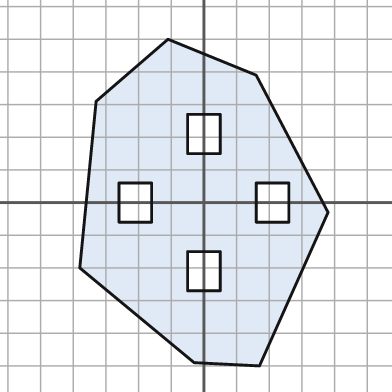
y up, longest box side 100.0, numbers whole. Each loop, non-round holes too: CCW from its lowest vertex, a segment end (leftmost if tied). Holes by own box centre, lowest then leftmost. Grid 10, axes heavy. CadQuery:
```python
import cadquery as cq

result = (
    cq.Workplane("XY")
    .moveTo(17.0, -50.0)
    .lineTo(38.0, -3.0)
    .lineTo(16.0, 39.0)
    .lineTo(-11.0, 50.0)
    .lineTo(-33.0, 31.0)
    .lineTo(-38.0, -20.0)
    .lineTo(-3.0, -49.0)
    .close()
    .moveTo(-5.0, -27.0)
    .lineTo(5.0, -27.0)
    .lineTo(5.0, -15.0)
    .lineTo(-5.0, -15.0)
    .close()
    .moveTo(-26.0, -6.0)
    .lineTo(-16.0, -6.0)
    .lineTo(-16.0, 6.0)
    .lineTo(-26.0, 6.0)
    .close()
    .moveTo(16.0, -6.0)
    .lineTo(26.0, -6.0)
    .lineTo(26.0, 6.0)
    .lineTo(16.0, 6.0)
    .close()
    .moveTo(-5.0, 15.0)
    .lineTo(5.0, 15.0)
    .lineTo(5.0, 27.0)
    .lineTo(-5.0, 27.0)
    .close()
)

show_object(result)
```